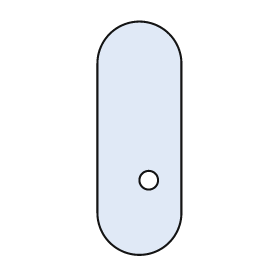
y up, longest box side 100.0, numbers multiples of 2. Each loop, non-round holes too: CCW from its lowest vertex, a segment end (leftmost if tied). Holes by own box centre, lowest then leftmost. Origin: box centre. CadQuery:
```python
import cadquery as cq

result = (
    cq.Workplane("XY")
    .moveTo(-18.0, -32.0)
    .threePointArc((0.0, -50.0), (18.0, -32.0))
    .lineTo(18.0, 32.0)
    .threePointArc((0.0, 50.0), (-18.0, 32.0))
    .close()
    .moveTo(4.0, -18.0)
    .circle(4.0)
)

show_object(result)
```